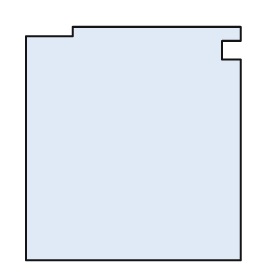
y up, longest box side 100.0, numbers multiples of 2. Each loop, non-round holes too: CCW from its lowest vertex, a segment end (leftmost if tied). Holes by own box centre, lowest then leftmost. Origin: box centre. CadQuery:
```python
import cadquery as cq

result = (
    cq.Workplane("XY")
    .moveTo(-46.0, -50.0)
    .lineTo(46.0, -50.0)
    .lineTo(46.0, 36.0)
    .lineTo(38.0, 36.0)
    .lineTo(38.0, 44.0)
    .lineTo(46.0, 44.0)
    .lineTo(46.0, 50.0)
    .lineTo(-26.0, 50.0)
    .lineTo(-26.0, 46.0)
    .lineTo(-46.0, 46.0)
    .close()
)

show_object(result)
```